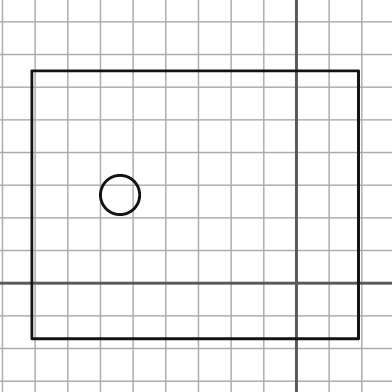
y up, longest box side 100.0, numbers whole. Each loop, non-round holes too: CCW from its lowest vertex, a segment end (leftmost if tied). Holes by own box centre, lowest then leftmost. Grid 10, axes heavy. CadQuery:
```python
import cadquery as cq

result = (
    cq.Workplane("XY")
    .moveTo(-81.0, -17.0)
    .lineTo(19.0, -17.0)
    .lineTo(19.0, 65.0)
    .lineTo(-81.0, 65.0)
    .close()
    .moveTo(-54.0, 27.0)
    .circle(6.0)
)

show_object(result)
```